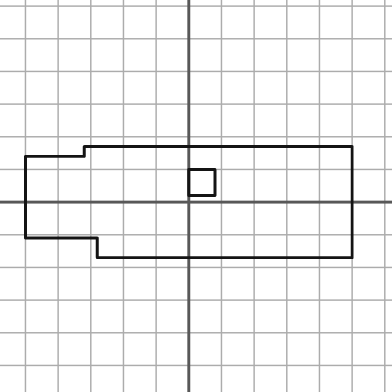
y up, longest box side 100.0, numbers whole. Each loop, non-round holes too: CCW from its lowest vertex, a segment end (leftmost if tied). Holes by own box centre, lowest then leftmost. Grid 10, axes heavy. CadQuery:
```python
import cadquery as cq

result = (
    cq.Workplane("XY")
    .moveTo(-28.0, -17.0)
    .lineTo(50.0, -17.0)
    .lineTo(50.0, 17.0)
    .lineTo(-32.0, 17.0)
    .lineTo(-32.0, 14.0)
    .lineTo(-50.0, 14.0)
    .lineTo(-50.0, -11.0)
    .lineTo(-28.0, -11.0)
    .close()
    .moveTo(0.0, 2.0)
    .lineTo(8.0, 2.0)
    .lineTo(8.0, 10.0)
    .lineTo(0.0, 10.0)
    .close()
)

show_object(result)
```